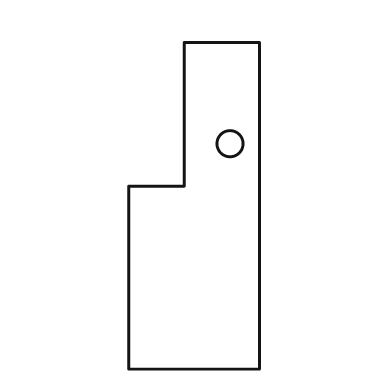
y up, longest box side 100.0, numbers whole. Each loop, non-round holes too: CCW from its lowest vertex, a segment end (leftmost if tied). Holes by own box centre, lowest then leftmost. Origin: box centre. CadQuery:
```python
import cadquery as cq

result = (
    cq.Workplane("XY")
    .moveTo(-20.0, -50.0)
    .lineTo(20.0, -50.0)
    .lineTo(20.0, 50.0)
    .lineTo(-3.0, 50.0)
    .lineTo(-3.0, 6.0)
    .lineTo(-20.0, 6.0)
    .close()
    .moveTo(11.0, 19.0)
    .circle(4.0)
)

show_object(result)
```